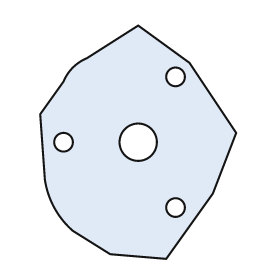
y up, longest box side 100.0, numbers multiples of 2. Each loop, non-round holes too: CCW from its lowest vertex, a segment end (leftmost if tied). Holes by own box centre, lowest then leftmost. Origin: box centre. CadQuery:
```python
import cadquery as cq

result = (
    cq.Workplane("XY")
    .moveTo(12.0, -50.0)
    .lineTo(32.0, -22.0)
    .lineTo(42.0, 4.0)
    .lineTo(22.0, 34.0)
    .lineTo(0.0, 50.0)
    .lineTo(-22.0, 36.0)
    .threePointArc((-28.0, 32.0), (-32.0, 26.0))
    .lineTo(-42.0, 12.0)
    .lineTo(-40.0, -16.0)
    .threePointArc((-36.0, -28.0), (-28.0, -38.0))
    .lineTo(-12.0, -48.0)
    .close()
    .moveTo(16.0, -28.0)
    .circle(4.0)
    .moveTo(-32.0, 0.0)
    .circle(4.0)
    .moveTo(0.0, 0.0)
    .circle(8.0)
    .moveTo(16.0, 28.0)
    .circle(4.0)
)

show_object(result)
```